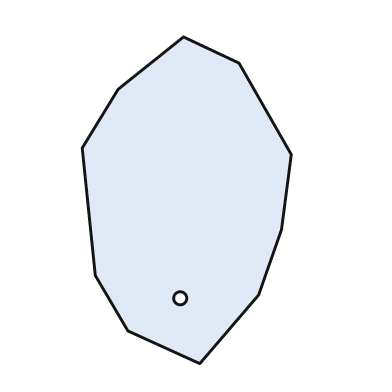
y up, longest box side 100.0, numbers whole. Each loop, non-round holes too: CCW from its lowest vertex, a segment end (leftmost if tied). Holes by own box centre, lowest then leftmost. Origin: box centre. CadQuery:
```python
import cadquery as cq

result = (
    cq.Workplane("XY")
    .moveTo(4.0, -50.0)
    .lineTo(22.0, -29.0)
    .lineTo(29.0, -9.0)
    .lineTo(32.0, 14.0)
    .lineTo(16.0, 42.0)
    .lineTo(-1.0, 50.0)
    .lineTo(-21.0, 34.0)
    .lineTo(-32.0, 16.0)
    .lineTo(-28.0, -23.0)
    .lineTo(-18.0, -40.0)
    .close()
    .moveTo(-2.0, -30.0)
    .circle(2.0)
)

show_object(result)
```